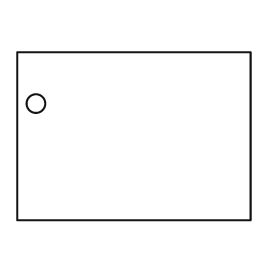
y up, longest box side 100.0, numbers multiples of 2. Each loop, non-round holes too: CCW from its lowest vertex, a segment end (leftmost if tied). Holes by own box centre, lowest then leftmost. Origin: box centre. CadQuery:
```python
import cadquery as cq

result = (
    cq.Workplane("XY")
    .moveTo(-50.0, -36.0)
    .lineTo(50.0, -36.0)
    .lineTo(50.0, 36.0)
    .lineTo(-50.0, 36.0)
    .close()
    .moveTo(-42.0, 14.0)
    .circle(4.0)
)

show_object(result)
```